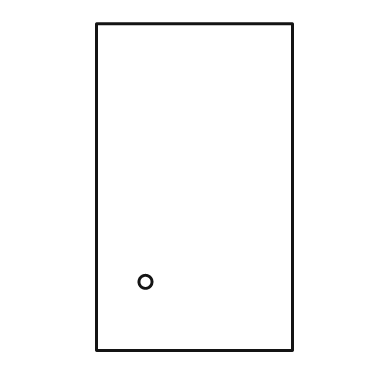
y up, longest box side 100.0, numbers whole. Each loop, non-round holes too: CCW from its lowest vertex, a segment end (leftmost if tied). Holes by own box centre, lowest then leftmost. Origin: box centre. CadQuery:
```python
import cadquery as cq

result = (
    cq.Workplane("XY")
    .moveTo(-30.0, -50.0)
    .lineTo(30.0, -50.0)
    .lineTo(30.0, 50.0)
    .lineTo(-30.0, 50.0)
    .close()
    .moveTo(-15.0, -29.0)
    .circle(2.0)
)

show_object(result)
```